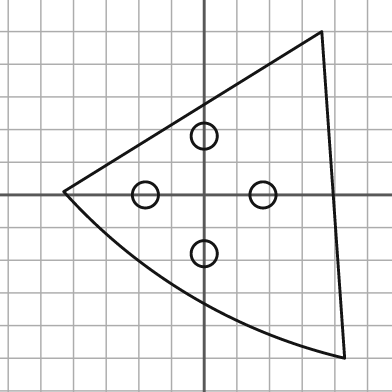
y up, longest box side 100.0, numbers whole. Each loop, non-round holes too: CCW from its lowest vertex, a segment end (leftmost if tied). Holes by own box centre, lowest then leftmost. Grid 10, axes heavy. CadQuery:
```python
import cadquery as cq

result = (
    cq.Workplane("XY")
    .moveTo(43.0, -50.0)
    .lineTo(36.0, 50.0)
    .lineTo(-43.0, 1.0)
    .threePointArc((-4.0, -31.0), (43.0, -50.0))
    .close()
    .moveTo(0.0, -18.0)
    .circle(4.0)
    .moveTo(-18.0, 0.0)
    .circle(4.0)
    .moveTo(18.0, 0.0)
    .circle(4.0)
    .moveTo(0.0, 18.0)
    .circle(4.0)
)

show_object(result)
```